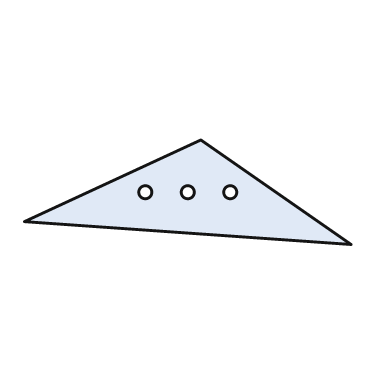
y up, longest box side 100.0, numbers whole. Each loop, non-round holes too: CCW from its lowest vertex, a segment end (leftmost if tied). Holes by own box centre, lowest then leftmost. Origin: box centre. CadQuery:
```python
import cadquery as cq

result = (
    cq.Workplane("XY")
    .moveTo(50.0, -16.0)
    .lineTo(4.0, 16.0)
    .lineTo(-50.0, -9.0)
    .close()
    .moveTo(-13.0, 0.0)
    .circle(2.0)
    .moveTo(0.0, 0.0)
    .circle(2.0)
    .moveTo(13.0, 0.0)
    .circle(2.0)
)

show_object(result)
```